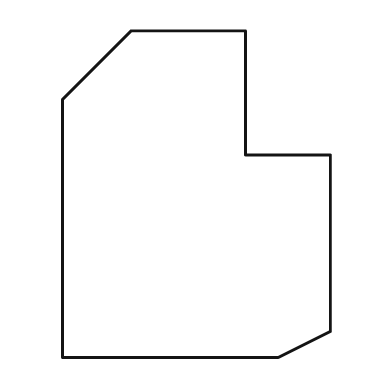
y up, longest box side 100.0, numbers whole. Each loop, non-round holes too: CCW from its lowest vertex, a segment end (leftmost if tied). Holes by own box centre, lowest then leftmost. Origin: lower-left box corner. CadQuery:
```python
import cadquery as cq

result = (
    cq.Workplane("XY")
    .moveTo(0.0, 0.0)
    .lineTo(66.0, 0.0)
    .lineTo(82.0, 8.0)
    .lineTo(82.0, 62.0)
    .lineTo(56.0, 62.0)
    .lineTo(56.0, 100.0)
    .lineTo(21.0, 100.0)
    .lineTo(0.0, 79.0)
    .close()
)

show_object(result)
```